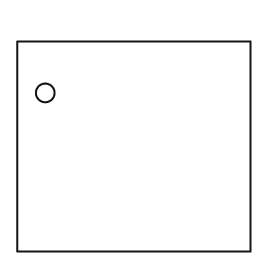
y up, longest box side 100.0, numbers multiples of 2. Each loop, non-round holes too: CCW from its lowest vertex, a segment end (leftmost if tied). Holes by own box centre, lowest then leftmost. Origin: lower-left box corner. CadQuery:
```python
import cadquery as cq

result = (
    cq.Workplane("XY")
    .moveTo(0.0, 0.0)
    .lineTo(100.0, 0.0)
    .lineTo(100.0, 90.0)
    .lineTo(0.0, 90.0)
    .close()
    .moveTo(12.0, 68.0)
    .circle(4.0)
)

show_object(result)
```